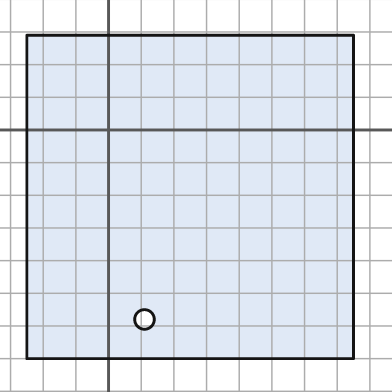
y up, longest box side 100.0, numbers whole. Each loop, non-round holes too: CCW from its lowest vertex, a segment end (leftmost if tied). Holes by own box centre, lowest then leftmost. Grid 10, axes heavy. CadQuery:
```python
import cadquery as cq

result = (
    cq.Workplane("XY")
    .moveTo(-25.0, -70.0)
    .lineTo(75.0, -70.0)
    .lineTo(75.0, 29.0)
    .lineTo(-25.0, 29.0)
    .close()
    .moveTo(11.0, -58.0)
    .circle(3.0)
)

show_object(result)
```